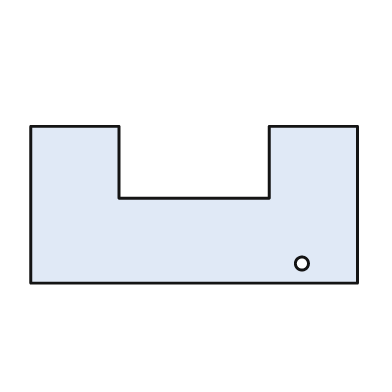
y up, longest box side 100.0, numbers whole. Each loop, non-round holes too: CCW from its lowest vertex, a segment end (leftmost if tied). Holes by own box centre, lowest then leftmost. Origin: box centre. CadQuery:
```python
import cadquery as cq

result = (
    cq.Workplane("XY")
    .moveTo(-50.0, -24.0)
    .lineTo(50.0, -24.0)
    .lineTo(50.0, 24.0)
    .lineTo(23.0, 24.0)
    .lineTo(23.0, 2.0)
    .lineTo(-23.0, 2.0)
    .lineTo(-23.0, 24.0)
    .lineTo(-50.0, 24.0)
    .close()
    .moveTo(33.0, -18.0)
    .circle(2.0)
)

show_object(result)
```